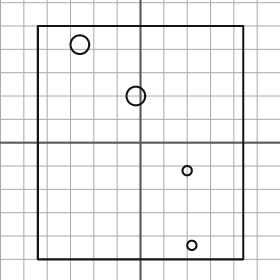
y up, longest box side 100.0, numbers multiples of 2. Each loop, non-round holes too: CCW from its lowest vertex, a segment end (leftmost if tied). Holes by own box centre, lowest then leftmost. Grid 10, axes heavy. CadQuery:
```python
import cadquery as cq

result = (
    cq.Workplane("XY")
    .moveTo(-44.0, -50.0)
    .lineTo(44.0, -50.0)
    .lineTo(44.0, 50.0)
    .lineTo(-44.0, 50.0)
    .close()
    .moveTo(22.0, -44.0)
    .circle(2.0)
    .moveTo(20.0, -12.0)
    .circle(2.0)
    .moveTo(-2.0, 20.0)
    .circle(4.0)
    .moveTo(-26.0, 42.0)
    .circle(4.0)
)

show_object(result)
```